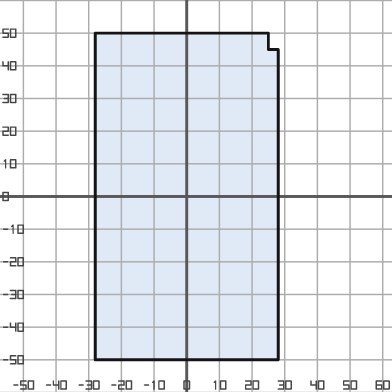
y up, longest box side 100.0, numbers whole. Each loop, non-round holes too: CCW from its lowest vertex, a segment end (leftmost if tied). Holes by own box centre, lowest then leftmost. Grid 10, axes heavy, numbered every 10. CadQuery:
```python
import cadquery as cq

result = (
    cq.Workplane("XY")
    .moveTo(-28.0, -50.0)
    .lineTo(28.0, -50.0)
    .lineTo(28.0, 45.0)
    .lineTo(25.0, 45.0)
    .lineTo(25.0, 50.0)
    .lineTo(-28.0, 50.0)
    .close()
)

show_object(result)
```